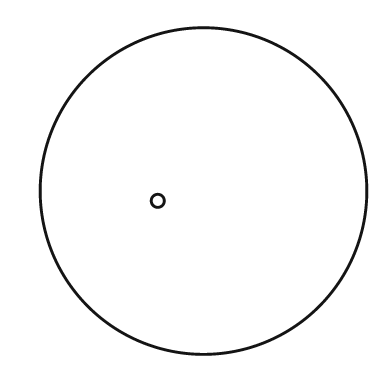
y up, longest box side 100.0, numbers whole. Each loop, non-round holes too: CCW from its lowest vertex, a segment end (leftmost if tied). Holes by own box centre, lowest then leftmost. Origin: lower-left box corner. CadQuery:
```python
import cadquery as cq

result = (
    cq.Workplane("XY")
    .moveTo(50.0, 50.0)
    .circle(50.0)
    .moveTo(36.0, 47.0)
    .circle(2.0)
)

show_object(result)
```